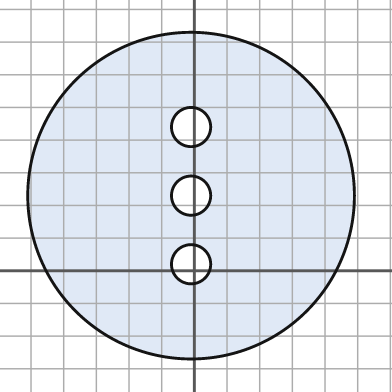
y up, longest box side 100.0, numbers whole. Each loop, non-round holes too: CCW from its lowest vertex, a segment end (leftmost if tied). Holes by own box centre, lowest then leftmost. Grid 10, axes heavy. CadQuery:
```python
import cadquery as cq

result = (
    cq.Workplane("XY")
    .moveTo(-1.0, 23.0)
    .circle(50.0)
    .moveTo(-1.0, 2.0)
    .circle(6.0)
    .moveTo(-1.0, 23.0)
    .circle(6.0)
    .moveTo(-1.0, 44.0)
    .circle(6.0)
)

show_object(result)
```